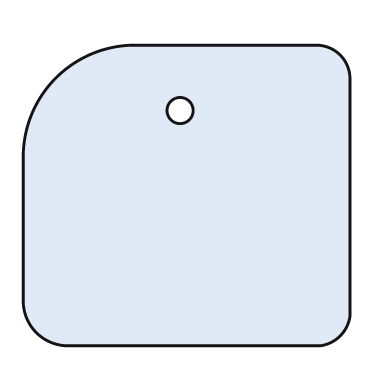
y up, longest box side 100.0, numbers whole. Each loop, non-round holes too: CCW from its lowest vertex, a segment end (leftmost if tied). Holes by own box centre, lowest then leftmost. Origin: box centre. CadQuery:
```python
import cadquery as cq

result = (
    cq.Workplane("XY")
    .moveTo(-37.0, -46.0)
    .lineTo(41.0, -46.0)
    .threePointArc((47.0, -43.0), (50.0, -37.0))
    .lineTo(50.0, 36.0)
    .threePointArc((47.0, 43.0), (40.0, 46.0))
    .lineTo(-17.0, 46.0)
    .threePointArc((-40.0, 36.0), (-50.0, 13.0))
    .lineTo(-50.0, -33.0)
    .threePointArc((-46.0, -42.0), (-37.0, -46.0))
    .close()
    .moveTo(-2.0, 26.0)
    .circle(4.0)
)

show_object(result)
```